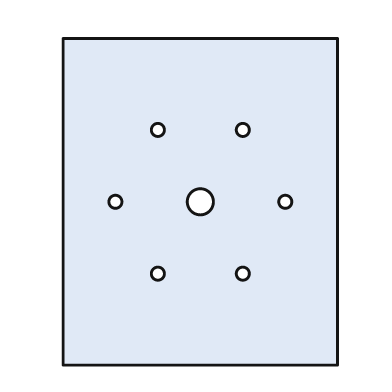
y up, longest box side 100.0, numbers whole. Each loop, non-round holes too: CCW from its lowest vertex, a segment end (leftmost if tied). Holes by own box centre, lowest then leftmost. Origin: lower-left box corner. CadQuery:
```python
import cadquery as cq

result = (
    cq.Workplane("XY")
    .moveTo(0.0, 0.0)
    .lineTo(84.0, 0.0)
    .lineTo(84.0, 100.0)
    .lineTo(0.0, 100.0)
    .close()
    .moveTo(29.0, 28.0)
    .circle(2.0)
    .moveTo(55.0, 28.0)
    .circle(2.0)
    .moveTo(16.0, 50.0)
    .circle(2.0)
    .moveTo(42.0, 50.0)
    .circle(4.0)
    .moveTo(68.0, 50.0)
    .circle(2.0)
    .moveTo(29.0, 72.0)
    .circle(2.0)
    .moveTo(55.0, 72.0)
    .circle(2.0)
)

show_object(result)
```